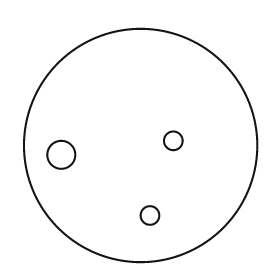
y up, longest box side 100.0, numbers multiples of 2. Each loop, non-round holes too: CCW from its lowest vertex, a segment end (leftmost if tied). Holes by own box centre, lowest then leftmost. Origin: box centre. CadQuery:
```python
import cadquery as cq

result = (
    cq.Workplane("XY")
    .moveTo(0.0, 0.0)
    .circle(50.0)
    .moveTo(4.0, -30.0)
    .circle(4.0)
    .moveTo(-34.0, -4.0)
    .circle(6.0)
    .moveTo(14.0, 2.0)
    .circle(4.0)
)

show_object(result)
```